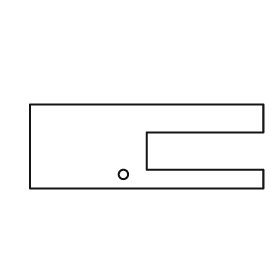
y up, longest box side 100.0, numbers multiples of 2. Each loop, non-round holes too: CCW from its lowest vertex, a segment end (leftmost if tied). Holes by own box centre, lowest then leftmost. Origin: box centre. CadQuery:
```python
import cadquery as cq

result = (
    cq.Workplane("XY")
    .moveTo(-50.0, -18.0)
    .lineTo(50.0, -18.0)
    .lineTo(50.0, -10.0)
    .lineTo(0.0, -10.0)
    .lineTo(0.0, 6.0)
    .lineTo(50.0, 6.0)
    .lineTo(50.0, 18.0)
    .lineTo(-50.0, 18.0)
    .close()
    .moveTo(-10.0, -12.0)
    .circle(2.0)
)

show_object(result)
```